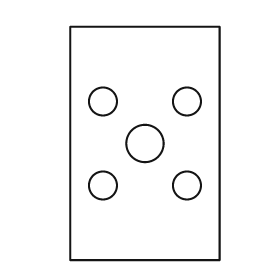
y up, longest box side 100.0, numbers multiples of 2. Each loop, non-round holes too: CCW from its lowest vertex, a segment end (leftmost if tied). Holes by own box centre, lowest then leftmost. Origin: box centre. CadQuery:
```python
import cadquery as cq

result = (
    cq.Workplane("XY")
    .moveTo(-32.0, -50.0)
    .lineTo(32.0, -50.0)
    .lineTo(32.0, 50.0)
    .lineTo(-32.0, 50.0)
    .close()
    .moveTo(-18.0, -18.0)
    .circle(6.0)
    .moveTo(18.0, -18.0)
    .circle(6.0)
    .moveTo(0.0, 0.0)
    .circle(8.0)
    .moveTo(-18.0, 18.0)
    .circle(6.0)
    .moveTo(18.0, 18.0)
    .circle(6.0)
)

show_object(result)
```